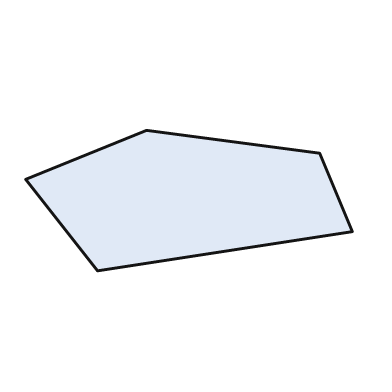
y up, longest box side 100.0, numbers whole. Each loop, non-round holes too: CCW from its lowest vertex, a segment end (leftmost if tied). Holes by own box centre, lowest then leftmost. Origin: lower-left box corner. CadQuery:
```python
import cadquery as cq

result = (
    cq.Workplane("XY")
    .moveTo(22.0, 0.0)
    .lineTo(100.0, 12.0)
    .lineTo(90.0, 36.0)
    .lineTo(37.0, 43.0)
    .lineTo(0.0, 28.0)
    .close()
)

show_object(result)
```